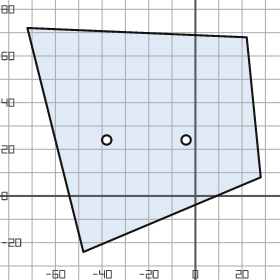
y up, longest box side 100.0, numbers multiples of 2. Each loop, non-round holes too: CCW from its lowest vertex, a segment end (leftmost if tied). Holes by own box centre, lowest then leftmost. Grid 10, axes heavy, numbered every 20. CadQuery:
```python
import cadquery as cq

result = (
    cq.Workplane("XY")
    .moveTo(-48.0, -24.0)
    .lineTo(28.0, 8.0)
    .lineTo(22.0, 68.0)
    .lineTo(-72.0, 72.0)
    .close()
    .moveTo(-38.0, 24.0)
    .circle(2.0)
    .moveTo(-4.0, 24.0)
    .circle(2.0)
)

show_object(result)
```